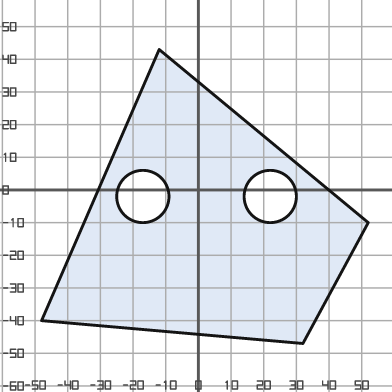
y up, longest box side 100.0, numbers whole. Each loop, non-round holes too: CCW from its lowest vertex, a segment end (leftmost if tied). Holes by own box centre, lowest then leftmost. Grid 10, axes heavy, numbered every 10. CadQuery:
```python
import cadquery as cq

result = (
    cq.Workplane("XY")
    .moveTo(32.0, -47.0)
    .lineTo(52.0, -10.0)
    .lineTo(-12.0, 43.0)
    .lineTo(-48.0, -40.0)
    .close()
    .moveTo(-17.0, -2.0)
    .circle(8.0)
    .moveTo(22.0, -2.0)
    .circle(8.0)
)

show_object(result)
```